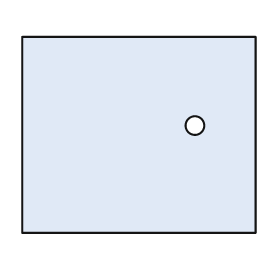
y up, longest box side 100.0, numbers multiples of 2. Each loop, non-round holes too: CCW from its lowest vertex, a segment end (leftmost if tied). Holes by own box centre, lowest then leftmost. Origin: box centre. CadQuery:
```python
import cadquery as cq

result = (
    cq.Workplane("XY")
    .moveTo(-50.0, -42.0)
    .lineTo(50.0, -42.0)
    .lineTo(50.0, 42.0)
    .lineTo(-50.0, 42.0)
    .close()
    .moveTo(24.0, 4.0)
    .circle(4.0)
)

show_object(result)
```